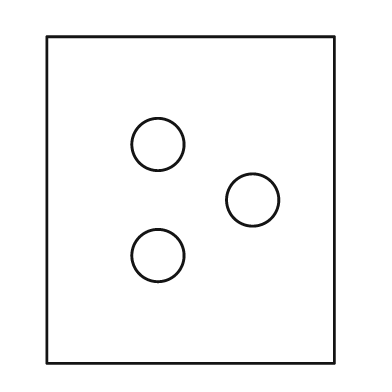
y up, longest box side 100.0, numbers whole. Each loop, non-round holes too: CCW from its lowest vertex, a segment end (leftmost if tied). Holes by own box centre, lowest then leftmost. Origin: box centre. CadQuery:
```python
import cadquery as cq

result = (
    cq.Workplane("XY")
    .moveTo(-44.0, -50.0)
    .lineTo(44.0, -50.0)
    .lineTo(44.0, 50.0)
    .lineTo(-44.0, 50.0)
    .close()
    .moveTo(-10.0, -17.0)
    .circle(8.0)
    .moveTo(19.0, 0.0)
    .circle(8.0)
    .moveTo(-10.0, 17.0)
    .circle(8.0)
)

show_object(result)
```